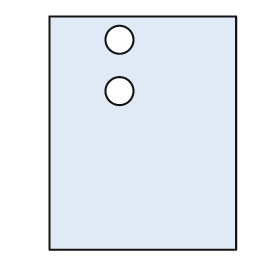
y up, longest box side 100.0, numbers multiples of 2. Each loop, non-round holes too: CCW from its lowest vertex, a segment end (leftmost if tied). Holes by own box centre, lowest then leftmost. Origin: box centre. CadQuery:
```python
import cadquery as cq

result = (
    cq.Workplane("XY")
    .moveTo(-40.0, -50.0)
    .lineTo(40.0, -50.0)
    .lineTo(40.0, 50.0)
    .lineTo(-40.0, 50.0)
    .close()
    .moveTo(-10.0, 18.0)
    .circle(6.0)
    .moveTo(-10.0, 40.0)
    .circle(6.0)
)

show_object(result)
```